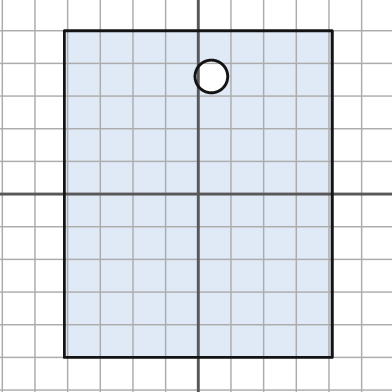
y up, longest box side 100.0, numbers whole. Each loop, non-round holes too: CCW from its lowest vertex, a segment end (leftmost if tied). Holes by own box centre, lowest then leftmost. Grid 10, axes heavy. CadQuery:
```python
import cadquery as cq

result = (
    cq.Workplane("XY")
    .moveTo(-41.0, -50.0)
    .lineTo(41.0, -50.0)
    .lineTo(41.0, 50.0)
    .lineTo(-41.0, 50.0)
    .close()
    .moveTo(4.0, 36.0)
    .circle(5.0)
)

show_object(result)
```